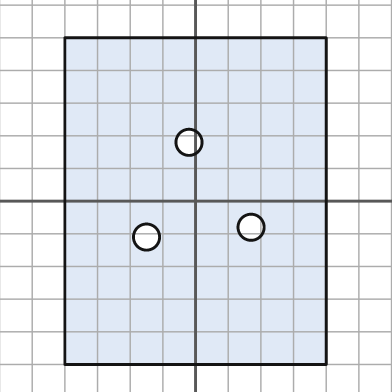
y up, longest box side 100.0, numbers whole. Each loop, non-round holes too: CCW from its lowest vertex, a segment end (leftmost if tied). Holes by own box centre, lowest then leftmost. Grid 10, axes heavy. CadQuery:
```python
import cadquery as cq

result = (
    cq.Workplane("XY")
    .moveTo(-40.0, -50.0)
    .lineTo(40.0, -50.0)
    .lineTo(40.0, 50.0)
    .lineTo(-40.0, 50.0)
    .close()
    .moveTo(-15.0, -11.0)
    .circle(4.0)
    .moveTo(17.0, -8.0)
    .circle(4.0)
    .moveTo(-2.0, 18.0)
    .circle(4.0)
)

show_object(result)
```